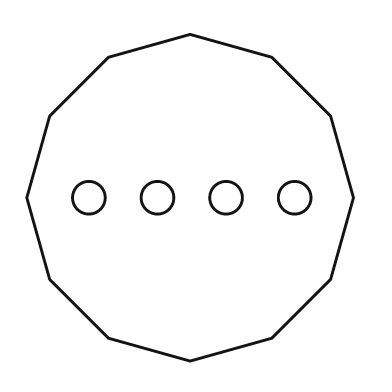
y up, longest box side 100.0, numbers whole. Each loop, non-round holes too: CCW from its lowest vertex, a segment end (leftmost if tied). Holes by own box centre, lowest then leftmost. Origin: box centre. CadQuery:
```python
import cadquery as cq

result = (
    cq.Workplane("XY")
    .moveTo(0.0, -50.0)
    .lineTo(25.0, -43.0)
    .lineTo(43.0, -25.0)
    .lineTo(50.0, 0.0)
    .lineTo(43.0, 25.0)
    .lineTo(25.0, 43.0)
    .lineTo(0.0, 50.0)
    .lineTo(-25.0, 43.0)
    .lineTo(-43.0, 25.0)
    .lineTo(-50.0, 0.0)
    .lineTo(-43.0, -25.0)
    .lineTo(-25.0, -43.0)
    .close()
    .moveTo(-31.0, 0.0)
    .circle(5.0)
    .moveTo(-10.0, 0.0)
    .circle(5.0)
    .moveTo(11.0, 0.0)
    .circle(5.0)
    .moveTo(32.0, 0.0)
    .circle(5.0)
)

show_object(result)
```